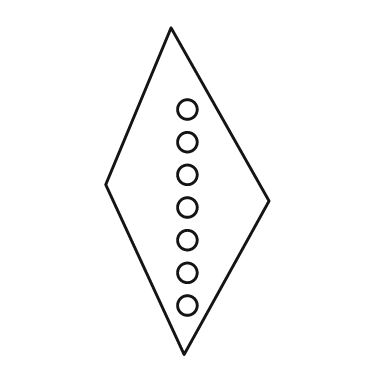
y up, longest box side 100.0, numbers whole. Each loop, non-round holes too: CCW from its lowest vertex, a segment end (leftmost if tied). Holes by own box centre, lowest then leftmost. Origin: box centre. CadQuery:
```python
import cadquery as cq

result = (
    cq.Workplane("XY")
    .moveTo(-1.0, -50.0)
    .lineTo(25.0, -3.0)
    .lineTo(-5.0, 50.0)
    .lineTo(-25.0, 2.0)
    .close()
    .moveTo(0.0, -35.0)
    .circle(3.0)
    .moveTo(0.0, -25.0)
    .circle(3.0)
    .moveTo(0.0, -15.0)
    .circle(3.0)
    .moveTo(0.0, -5.0)
    .circle(3.0)
    .moveTo(0.0, 5.0)
    .circle(3.0)
    .moveTo(0.0, 15.0)
    .circle(3.0)
    .moveTo(0.0, 25.0)
    .circle(3.0)
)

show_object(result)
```